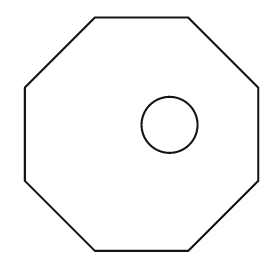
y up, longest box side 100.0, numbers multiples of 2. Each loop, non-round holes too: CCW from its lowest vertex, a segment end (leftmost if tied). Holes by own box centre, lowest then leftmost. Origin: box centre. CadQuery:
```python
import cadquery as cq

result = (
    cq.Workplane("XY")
    .moveTo(-20.0, -50.0)
    .lineTo(20.0, -50.0)
    .lineTo(50.0, -20.0)
    .lineTo(50.0, 20.0)
    .lineTo(20.0, 50.0)
    .lineTo(-20.0, 50.0)
    .lineTo(-50.0, 20.0)
    .lineTo(-50.0, -20.0)
    .close()
    .moveTo(12.0, 4.0)
    .circle(12.0)
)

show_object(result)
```